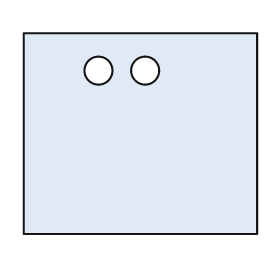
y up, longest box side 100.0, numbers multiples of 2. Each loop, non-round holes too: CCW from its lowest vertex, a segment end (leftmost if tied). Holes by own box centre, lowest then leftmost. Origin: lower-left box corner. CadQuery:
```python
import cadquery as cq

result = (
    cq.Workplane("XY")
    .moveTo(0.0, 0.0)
    .lineTo(100.0, 0.0)
    .lineTo(100.0, 86.0)
    .lineTo(0.0, 86.0)
    .close()
    .moveTo(32.0, 70.0)
    .circle(6.0)
    .moveTo(52.0, 70.0)
    .circle(6.0)
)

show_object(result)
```